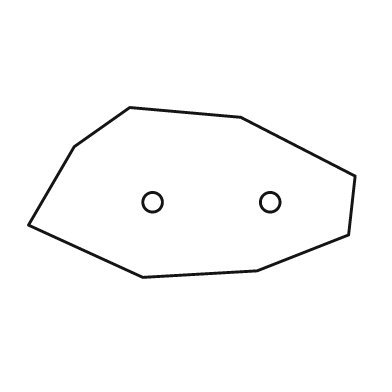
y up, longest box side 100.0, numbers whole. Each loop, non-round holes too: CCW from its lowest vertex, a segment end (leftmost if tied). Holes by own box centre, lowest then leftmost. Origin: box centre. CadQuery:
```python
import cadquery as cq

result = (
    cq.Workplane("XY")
    .moveTo(-15.0, -26.0)
    .lineTo(20.0, -24.0)
    .lineTo(48.0, -13.0)
    .lineTo(50.0, 5.0)
    .lineTo(15.0, 23.0)
    .lineTo(-19.0, 26.0)
    .lineTo(-36.0, 14.0)
    .lineTo(-50.0, -10.0)
    .close()
    .moveTo(-12.0, -3.0)
    .circle(3.0)
    .moveTo(24.0, -3.0)
    .circle(3.0)
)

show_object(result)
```